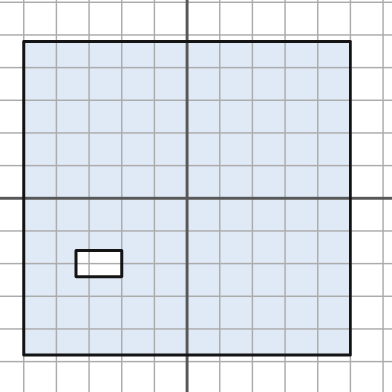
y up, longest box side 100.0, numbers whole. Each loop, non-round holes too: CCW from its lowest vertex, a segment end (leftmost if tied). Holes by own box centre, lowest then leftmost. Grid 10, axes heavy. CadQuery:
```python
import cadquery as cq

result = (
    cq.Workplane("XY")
    .moveTo(-50.0, -48.0)
    .lineTo(50.0, -48.0)
    .lineTo(50.0, 48.0)
    .lineTo(-50.0, 48.0)
    .close()
    .moveTo(-34.0, -24.0)
    .lineTo(-20.0, -24.0)
    .lineTo(-20.0, -16.0)
    .lineTo(-34.0, -16.0)
    .close()
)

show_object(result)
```